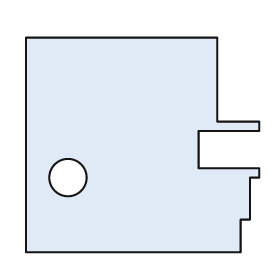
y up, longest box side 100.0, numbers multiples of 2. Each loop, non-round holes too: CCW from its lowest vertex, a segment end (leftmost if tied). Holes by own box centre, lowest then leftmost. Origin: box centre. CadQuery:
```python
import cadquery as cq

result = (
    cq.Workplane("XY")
    .moveTo(-50.0, -46.0)
    .lineTo(42.0, -46.0)
    .lineTo(42.0, -32.0)
    .lineTo(46.0, -32.0)
    .lineTo(46.0, -14.0)
    .lineTo(50.0, -14.0)
    .lineTo(50.0, -10.0)
    .lineTo(24.0, -10.0)
    .lineTo(24.0, 6.0)
    .lineTo(50.0, 6.0)
    .lineTo(50.0, 10.0)
    .lineTo(32.0, 10.0)
    .lineTo(32.0, 46.0)
    .lineTo(-50.0, 46.0)
    .close()
    .moveTo(-32.0, -14.0)
    .circle(8.0)
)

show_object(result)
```